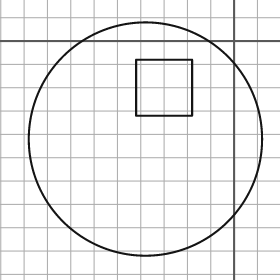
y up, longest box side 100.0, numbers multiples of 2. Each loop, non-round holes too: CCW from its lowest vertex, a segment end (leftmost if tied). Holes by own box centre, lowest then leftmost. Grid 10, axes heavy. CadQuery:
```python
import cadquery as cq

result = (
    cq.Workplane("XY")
    .moveTo(-38.0, -42.0)
    .circle(50.0)
    .moveTo(-42.0, -32.0)
    .lineTo(-18.0, -32.0)
    .lineTo(-18.0, -8.0)
    .lineTo(-42.0, -8.0)
    .close()
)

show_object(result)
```